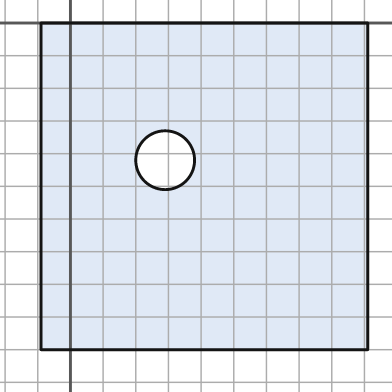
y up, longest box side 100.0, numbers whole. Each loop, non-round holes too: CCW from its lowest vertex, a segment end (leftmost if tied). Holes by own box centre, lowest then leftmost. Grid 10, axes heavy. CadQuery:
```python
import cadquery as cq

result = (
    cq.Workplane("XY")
    .moveTo(-9.0, -100.0)
    .lineTo(91.0, -100.0)
    .lineTo(91.0, 0.0)
    .lineTo(-9.0, 0.0)
    .close()
    .moveTo(29.0, -42.0)
    .circle(9.0)
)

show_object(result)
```